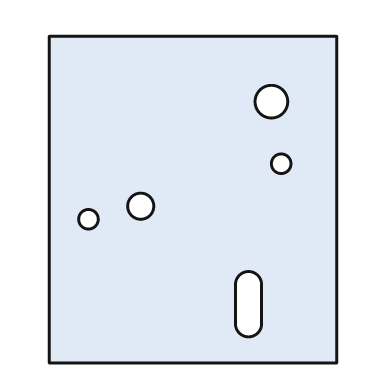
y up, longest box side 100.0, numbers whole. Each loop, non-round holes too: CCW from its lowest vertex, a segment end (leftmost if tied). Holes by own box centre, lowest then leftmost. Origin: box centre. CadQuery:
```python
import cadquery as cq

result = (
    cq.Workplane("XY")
    .moveTo(-44.0, -50.0)
    .lineTo(44.0, -50.0)
    .lineTo(44.0, 50.0)
    .lineTo(-44.0, 50.0)
    .close()
    .moveTo(13.0, -38.0)
    .threePointArc((17.0, -42.0), (21.0, -38.0))
    .lineTo(21.0, -26.0)
    .threePointArc((17.0, -22.0), (13.0, -26.0))
    .close()
    .moveTo(-32.0, -6.0)
    .circle(3.0)
    .moveTo(-16.0, -2.0)
    .circle(4.0)
    .moveTo(27.0, 11.0)
    .circle(3.0)
    .moveTo(24.0, 30.0)
    .circle(5.0)
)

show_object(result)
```